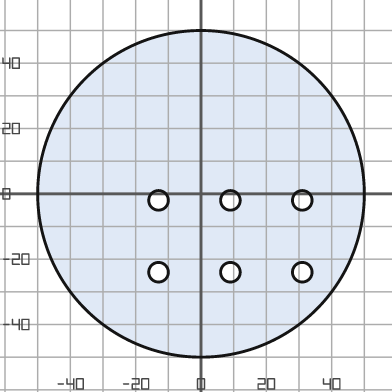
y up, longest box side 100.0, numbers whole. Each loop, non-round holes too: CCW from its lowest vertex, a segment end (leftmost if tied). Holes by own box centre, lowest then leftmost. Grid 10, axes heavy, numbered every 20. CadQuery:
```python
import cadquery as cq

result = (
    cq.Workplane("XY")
    .moveTo(0.0, 0.0)
    .circle(50.0)
    .moveTo(-13.0, -24.0)
    .circle(3.0)
    .moveTo(9.0, -24.0)
    .circle(3.0)
    .moveTo(31.0, -24.0)
    .circle(3.0)
    .moveTo(-13.0, -2.0)
    .circle(3.0)
    .moveTo(9.0, -2.0)
    .circle(3.0)
    .moveTo(31.0, -2.0)
    .circle(3.0)
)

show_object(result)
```